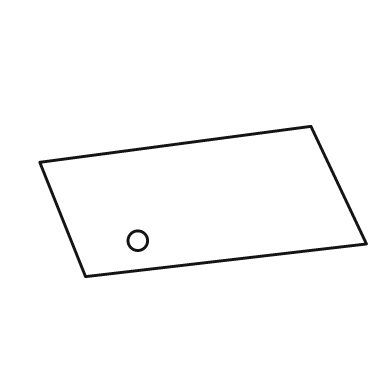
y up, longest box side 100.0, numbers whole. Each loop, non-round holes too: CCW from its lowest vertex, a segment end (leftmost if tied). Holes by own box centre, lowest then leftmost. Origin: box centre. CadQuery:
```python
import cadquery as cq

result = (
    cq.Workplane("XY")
    .moveTo(-36.0, -23.0)
    .lineTo(50.0, -13.0)
    .lineTo(33.0, 23.0)
    .lineTo(-50.0, 12.0)
    .close()
    .moveTo(-20.0, -12.0)
    .circle(3.0)
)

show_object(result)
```